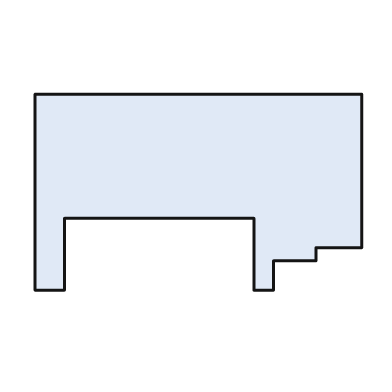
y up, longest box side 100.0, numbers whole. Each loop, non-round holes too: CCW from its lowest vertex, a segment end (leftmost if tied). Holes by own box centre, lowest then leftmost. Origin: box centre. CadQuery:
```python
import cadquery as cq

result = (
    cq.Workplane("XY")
    .moveTo(-50.0, -30.0)
    .lineTo(-41.0, -30.0)
    .lineTo(-41.0, -8.0)
    .lineTo(17.0, -8.0)
    .lineTo(17.0, -30.0)
    .lineTo(23.0, -30.0)
    .lineTo(23.0, -21.0)
    .lineTo(36.0, -21.0)
    .lineTo(36.0, -17.0)
    .lineTo(50.0, -17.0)
    .lineTo(50.0, 30.0)
    .lineTo(-50.0, 30.0)
    .close()
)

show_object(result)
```